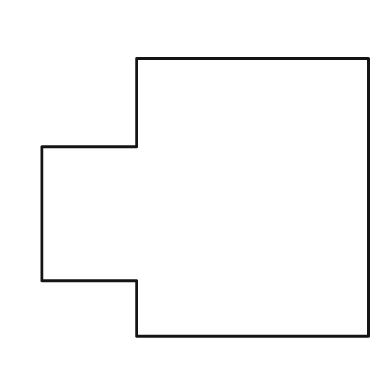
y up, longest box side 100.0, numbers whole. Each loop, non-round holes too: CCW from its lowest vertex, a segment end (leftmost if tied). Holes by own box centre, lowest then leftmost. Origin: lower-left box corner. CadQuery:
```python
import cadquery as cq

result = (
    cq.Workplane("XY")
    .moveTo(29.0, 0.0)
    .lineTo(100.0, 0.0)
    .lineTo(100.0, 85.0)
    .lineTo(29.0, 85.0)
    .lineTo(29.0, 58.0)
    .lineTo(0.0, 58.0)
    .lineTo(0.0, 17.0)
    .lineTo(29.0, 17.0)
    .close()
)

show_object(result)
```